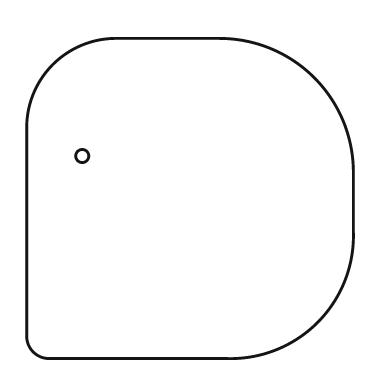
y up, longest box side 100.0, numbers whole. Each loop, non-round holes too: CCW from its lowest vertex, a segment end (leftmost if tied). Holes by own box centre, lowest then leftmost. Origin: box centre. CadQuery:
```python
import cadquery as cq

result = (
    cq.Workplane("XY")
    .moveTo(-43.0, -49.0)
    .lineTo(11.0, -49.0)
    .threePointArc((39.0, -38.0), (50.0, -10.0))
    .lineTo(50.0, 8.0)
    .threePointArc((38.0, 37.0), (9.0, 49.0))
    .lineTo(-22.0, 49.0)
    .threePointArc((-42.0, 41.0), (-50.0, 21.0))
    .lineTo(-50.0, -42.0)
    .threePointArc((-48.0, -47.0), (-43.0, -49.0))
    .close()
    .moveTo(-33.0, 13.0)
    .circle(2.0)
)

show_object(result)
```